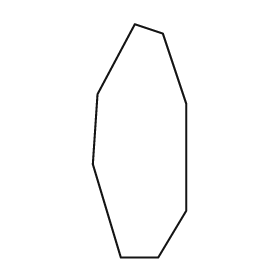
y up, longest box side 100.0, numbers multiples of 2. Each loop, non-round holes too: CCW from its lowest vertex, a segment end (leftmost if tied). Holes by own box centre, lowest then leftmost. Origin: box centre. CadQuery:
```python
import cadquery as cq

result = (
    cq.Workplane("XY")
    .moveTo(-8.0, -50.0)
    .lineTo(8.0, -50.0)
    .lineTo(20.0, -30.0)
    .lineTo(20.0, 16.0)
    .lineTo(10.0, 46.0)
    .lineTo(-2.0, 50.0)
    .lineTo(-18.0, 20.0)
    .lineTo(-20.0, -10.0)
    .close()
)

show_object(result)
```